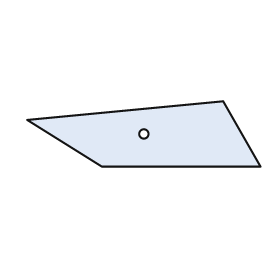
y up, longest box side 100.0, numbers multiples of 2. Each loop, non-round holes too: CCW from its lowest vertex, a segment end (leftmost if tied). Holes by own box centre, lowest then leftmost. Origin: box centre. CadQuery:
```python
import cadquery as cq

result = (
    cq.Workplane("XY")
    .moveTo(-18.0, -14.0)
    .lineTo(50.0, -14.0)
    .lineTo(34.0, 14.0)
    .lineTo(-50.0, 6.0)
    .close()
    .moveTo(0.0, 0.0)
    .circle(2.0)
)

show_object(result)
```